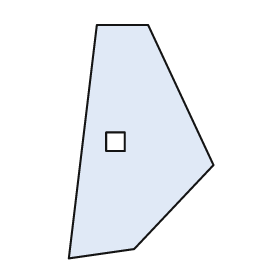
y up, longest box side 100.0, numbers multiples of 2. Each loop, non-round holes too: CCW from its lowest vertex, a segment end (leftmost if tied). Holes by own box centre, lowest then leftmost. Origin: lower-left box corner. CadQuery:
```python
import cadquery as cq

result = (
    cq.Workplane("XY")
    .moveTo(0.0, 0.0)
    .lineTo(28.0, 4.0)
    .lineTo(62.0, 40.0)
    .lineTo(34.0, 100.0)
    .lineTo(12.0, 100.0)
    .close()
    .moveTo(16.0, 46.0)
    .lineTo(24.0, 46.0)
    .lineTo(24.0, 54.0)
    .lineTo(16.0, 54.0)
    .close()
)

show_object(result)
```